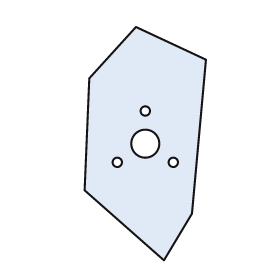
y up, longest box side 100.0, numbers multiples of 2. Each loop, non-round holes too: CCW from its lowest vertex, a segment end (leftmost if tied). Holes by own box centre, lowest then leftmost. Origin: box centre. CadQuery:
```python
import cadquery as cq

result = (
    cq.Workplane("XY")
    .moveTo(8.0, -50.0)
    .lineTo(20.0, -30.0)
    .lineTo(26.0, 36.0)
    .lineTo(-4.0, 50.0)
    .lineTo(-24.0, 28.0)
    .lineTo(-26.0, -20.0)
    .close()
    .moveTo(-12.0, -8.0)
    .circle(2.0)
    .moveTo(12.0, -8.0)
    .circle(2.0)
    .moveTo(0.0, 0.0)
    .circle(6.0)
    .moveTo(0.0, 14.0)
    .circle(2.0)
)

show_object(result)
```